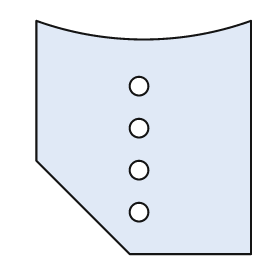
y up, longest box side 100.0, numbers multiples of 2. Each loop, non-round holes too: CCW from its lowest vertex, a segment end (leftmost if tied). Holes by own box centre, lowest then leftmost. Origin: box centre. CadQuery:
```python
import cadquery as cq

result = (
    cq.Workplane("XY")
    .moveTo(-6.0, -50.0)
    .lineTo(46.0, -50.0)
    .lineTo(46.0, 50.0)
    .threePointArc((0.0, 42.0), (-46.0, 50.0))
    .lineTo(-46.0, -10.0)
    .close()
    .moveTo(-2.0, -32.0)
    .circle(4.0)
    .moveTo(-2.0, -14.0)
    .circle(4.0)
    .moveTo(-2.0, 4.0)
    .circle(4.0)
    .moveTo(-2.0, 22.0)
    .circle(4.0)
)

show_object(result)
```